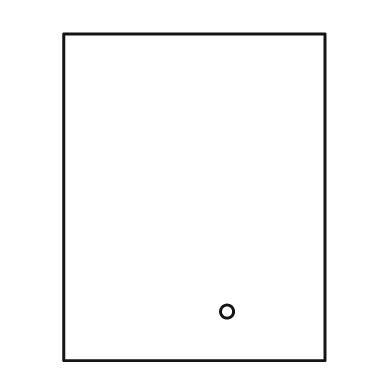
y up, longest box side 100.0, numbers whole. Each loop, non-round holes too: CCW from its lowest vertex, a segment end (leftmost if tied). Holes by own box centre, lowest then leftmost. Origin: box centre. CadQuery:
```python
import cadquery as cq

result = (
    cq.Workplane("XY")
    .moveTo(-40.0, -50.0)
    .lineTo(40.0, -50.0)
    .lineTo(40.0, 50.0)
    .lineTo(-40.0, 50.0)
    .close()
    .moveTo(10.0, -35.0)
    .circle(2.0)
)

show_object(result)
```